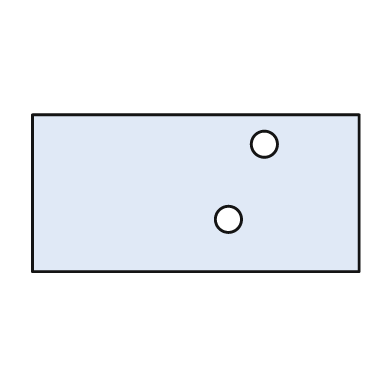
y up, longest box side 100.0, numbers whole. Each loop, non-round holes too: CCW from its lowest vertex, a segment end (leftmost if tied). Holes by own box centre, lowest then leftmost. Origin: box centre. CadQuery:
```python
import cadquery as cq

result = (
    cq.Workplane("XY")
    .moveTo(-50.0, -24.0)
    .lineTo(50.0, -24.0)
    .lineTo(50.0, 24.0)
    .lineTo(-50.0, 24.0)
    .close()
    .moveTo(10.0, -8.0)
    .circle(4.0)
    .moveTo(21.0, 15.0)
    .circle(4.0)
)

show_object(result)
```